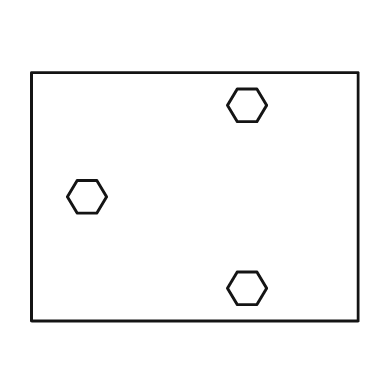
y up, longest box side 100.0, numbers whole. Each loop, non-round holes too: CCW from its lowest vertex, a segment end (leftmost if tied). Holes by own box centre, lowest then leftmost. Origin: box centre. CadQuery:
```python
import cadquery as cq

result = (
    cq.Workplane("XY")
    .moveTo(-50.0, -38.0)
    .lineTo(50.0, -38.0)
    .lineTo(50.0, 38.0)
    .lineTo(-50.0, 38.0)
    .close()
    .moveTo(13.0, -33.0)
    .lineTo(19.0, -33.0)
    .lineTo(22.0, -28.0)
    .lineTo(19.0, -23.0)
    .lineTo(13.0, -23.0)
    .lineTo(10.0, -28.0)
    .close()
    .moveTo(-36.0, -5.0)
    .lineTo(-30.0, -5.0)
    .lineTo(-27.0, 0.0)
    .lineTo(-30.0, 5.0)
    .lineTo(-36.0, 5.0)
    .lineTo(-39.0, 0.0)
    .close()
    .moveTo(13.0, 23.0)
    .lineTo(19.0, 23.0)
    .lineTo(22.0, 28.0)
    .lineTo(19.0, 33.0)
    .lineTo(13.0, 33.0)
    .lineTo(10.0, 28.0)
    .close()
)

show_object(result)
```